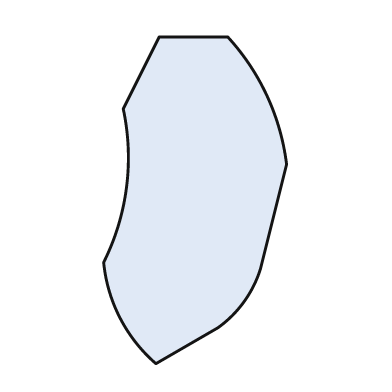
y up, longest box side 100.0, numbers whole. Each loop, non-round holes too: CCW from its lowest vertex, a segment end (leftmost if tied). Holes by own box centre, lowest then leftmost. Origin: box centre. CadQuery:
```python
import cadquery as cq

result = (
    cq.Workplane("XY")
    .moveTo(-12.0, -50.0)
    .lineTo(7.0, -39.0)
    .threePointArc((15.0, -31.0), (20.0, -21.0))
    .lineTo(28.0, 11.0)
    .threePointArc((22.0, 32.0), (10.0, 50.0))
    .lineTo(-11.0, 50.0)
    .lineTo(-22.0, 28.0)
    .threePointArc((-21.0, 4.0), (-28.0, -19.0))
    .threePointArc((-23.0, -36.0), (-12.0, -50.0))
    .close()
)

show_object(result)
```